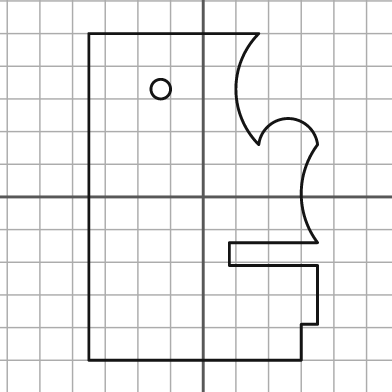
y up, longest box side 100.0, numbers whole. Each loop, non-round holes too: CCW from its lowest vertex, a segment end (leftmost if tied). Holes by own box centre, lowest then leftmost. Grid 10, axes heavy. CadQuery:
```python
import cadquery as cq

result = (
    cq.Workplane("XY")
    .moveTo(-35.0, -50.0)
    .lineTo(30.0, -50.0)
    .lineTo(30.0, -39.0)
    .lineTo(35.0, -39.0)
    .lineTo(35.0, -21.0)
    .lineTo(8.0, -21.0)
    .lineTo(8.0, -14.0)
    .lineTo(35.0, -14.0)
    .threePointArc((30.0, 1.0), (35.0, 16.0))
    .threePointArc((26.0, 24.0), (17.0, 16.0))
    .threePointArc((10.0, 33.0), (17.0, 50.0))
    .lineTo(-35.0, 50.0)
    .close()
    .moveTo(-13.0, 33.0)
    .circle(3.0)
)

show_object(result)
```